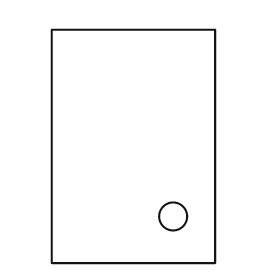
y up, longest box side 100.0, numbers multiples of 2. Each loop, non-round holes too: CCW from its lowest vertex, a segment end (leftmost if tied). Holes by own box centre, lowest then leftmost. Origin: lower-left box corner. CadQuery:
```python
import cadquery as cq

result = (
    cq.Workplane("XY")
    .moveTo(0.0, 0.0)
    .lineTo(70.0, 0.0)
    .lineTo(70.0, 100.0)
    .lineTo(0.0, 100.0)
    .close()
    .moveTo(52.0, 20.0)
    .circle(6.0)
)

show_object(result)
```